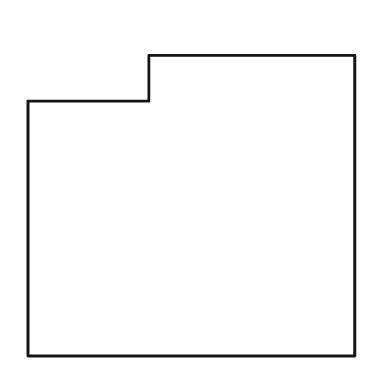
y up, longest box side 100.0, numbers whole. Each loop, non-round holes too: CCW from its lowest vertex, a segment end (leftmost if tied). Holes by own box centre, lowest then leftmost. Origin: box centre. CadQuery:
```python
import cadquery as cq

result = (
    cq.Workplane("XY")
    .moveTo(-50.0, -46.0)
    .lineTo(50.0, -46.0)
    .lineTo(50.0, 46.0)
    .lineTo(-13.0, 46.0)
    .lineTo(-13.0, 32.0)
    .lineTo(-50.0, 32.0)
    .close()
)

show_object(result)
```